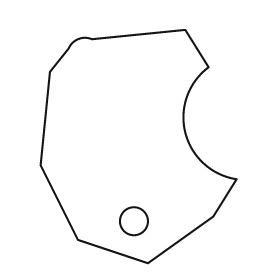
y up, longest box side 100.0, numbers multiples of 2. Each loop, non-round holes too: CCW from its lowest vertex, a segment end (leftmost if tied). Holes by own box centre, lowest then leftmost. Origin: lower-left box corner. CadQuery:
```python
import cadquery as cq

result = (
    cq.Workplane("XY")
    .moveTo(46.0, 0.0)
    .lineTo(74.0, 20.0)
    .lineTo(84.0, 36.0)
    .threePointArc((62.0, 56.0), (72.0, 84.0))
    .lineTo(62.0, 100.0)
    .lineTo(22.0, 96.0)
    .threePointArc((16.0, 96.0), (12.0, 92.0))
    .lineTo(4.0, 82.0)
    .lineTo(0.0, 42.0)
    .lineTo(16.0, 10.0)
    .close()
    .moveTo(40.0, 18.0)
    .circle(6.0)
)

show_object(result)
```